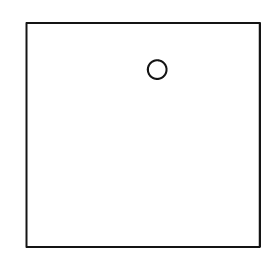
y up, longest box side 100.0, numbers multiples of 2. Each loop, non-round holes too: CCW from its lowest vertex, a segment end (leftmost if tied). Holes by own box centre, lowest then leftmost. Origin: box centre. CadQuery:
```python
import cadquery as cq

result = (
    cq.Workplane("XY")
    .moveTo(-50.0, -48.0)
    .lineTo(50.0, -48.0)
    .lineTo(50.0, 48.0)
    .lineTo(-50.0, 48.0)
    .close()
    .moveTo(6.0, 28.0)
    .circle(4.0)
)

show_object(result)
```